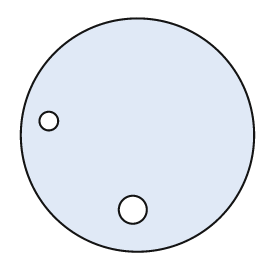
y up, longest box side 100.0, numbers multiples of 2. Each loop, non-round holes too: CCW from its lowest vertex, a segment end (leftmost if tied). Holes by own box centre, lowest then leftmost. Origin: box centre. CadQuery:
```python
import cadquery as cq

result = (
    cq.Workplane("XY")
    .moveTo(0.0, 0.0)
    .circle(50.0)
    .moveTo(-2.0, -32.0)
    .circle(6.0)
    .moveTo(-38.0, 6.0)
    .circle(4.0)
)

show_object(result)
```